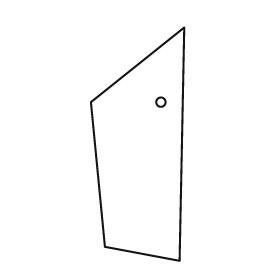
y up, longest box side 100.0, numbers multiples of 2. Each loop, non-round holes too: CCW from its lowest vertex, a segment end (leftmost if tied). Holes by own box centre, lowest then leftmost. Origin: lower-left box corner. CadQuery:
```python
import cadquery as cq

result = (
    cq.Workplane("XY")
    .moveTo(38.0, 0.0)
    .lineTo(40.0, 100.0)
    .lineTo(0.0, 68.0)
    .lineTo(6.0, 6.0)
    .close()
    .moveTo(30.0, 68.0)
    .circle(2.0)
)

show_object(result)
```